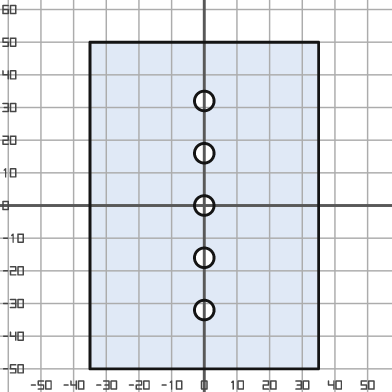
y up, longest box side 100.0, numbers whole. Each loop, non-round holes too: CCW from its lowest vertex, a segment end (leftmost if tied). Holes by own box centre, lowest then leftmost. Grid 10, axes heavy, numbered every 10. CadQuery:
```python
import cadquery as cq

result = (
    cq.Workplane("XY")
    .moveTo(-35.0, -50.0)
    .lineTo(35.0, -50.0)
    .lineTo(35.0, 50.0)
    .lineTo(-35.0, 50.0)
    .close()
    .moveTo(0.0, -32.0)
    .circle(3.0)
    .moveTo(0.0, -16.0)
    .circle(3.0)
    .moveTo(0.0, 0.0)
    .circle(3.0)
    .moveTo(0.0, 16.0)
    .circle(3.0)
    .moveTo(0.0, 32.0)
    .circle(3.0)
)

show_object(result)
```